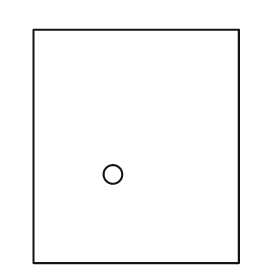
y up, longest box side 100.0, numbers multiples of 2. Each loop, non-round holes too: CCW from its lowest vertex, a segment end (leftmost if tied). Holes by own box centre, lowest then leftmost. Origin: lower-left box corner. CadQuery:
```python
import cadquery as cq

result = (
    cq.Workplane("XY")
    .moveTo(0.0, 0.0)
    .lineTo(88.0, 0.0)
    .lineTo(88.0, 100.0)
    .lineTo(0.0, 100.0)
    .close()
    .moveTo(34.0, 38.0)
    .circle(4.0)
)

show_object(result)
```